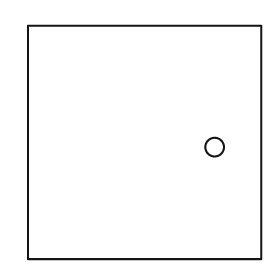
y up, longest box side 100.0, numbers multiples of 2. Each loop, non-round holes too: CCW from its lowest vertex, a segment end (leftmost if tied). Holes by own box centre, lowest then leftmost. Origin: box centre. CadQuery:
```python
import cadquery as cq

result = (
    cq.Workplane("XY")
    .moveTo(-50.0, -50.0)
    .lineTo(50.0, -50.0)
    .lineTo(50.0, 50.0)
    .lineTo(-50.0, 50.0)
    .close()
    .moveTo(30.0, -2.0)
    .circle(4.0)
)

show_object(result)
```